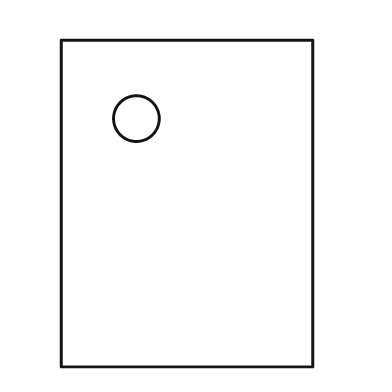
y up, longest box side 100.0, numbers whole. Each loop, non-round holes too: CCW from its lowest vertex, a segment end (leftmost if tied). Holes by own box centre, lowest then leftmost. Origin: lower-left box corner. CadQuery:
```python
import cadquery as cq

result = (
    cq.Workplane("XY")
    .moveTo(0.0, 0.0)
    .lineTo(77.0, 0.0)
    .lineTo(77.0, 100.0)
    .lineTo(0.0, 100.0)
    .close()
    .moveTo(23.0, 76.0)
    .circle(7.0)
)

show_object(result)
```